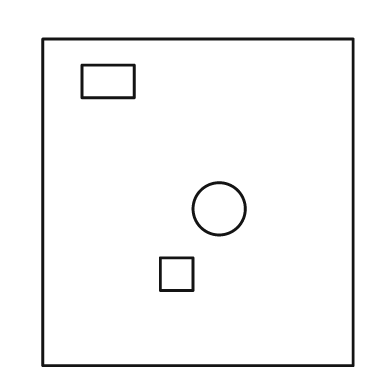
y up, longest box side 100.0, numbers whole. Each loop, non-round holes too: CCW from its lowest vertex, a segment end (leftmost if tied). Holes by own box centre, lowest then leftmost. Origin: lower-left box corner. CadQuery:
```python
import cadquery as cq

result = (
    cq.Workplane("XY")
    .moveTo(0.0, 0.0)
    .lineTo(95.0, 0.0)
    .lineTo(95.0, 100.0)
    .lineTo(0.0, 100.0)
    .close()
    .moveTo(36.0, 23.0)
    .lineTo(46.0, 23.0)
    .lineTo(46.0, 33.0)
    .lineTo(36.0, 33.0)
    .close()
    .moveTo(54.0, 48.0)
    .circle(8.0)
    .moveTo(12.0, 82.0)
    .lineTo(28.0, 82.0)
    .lineTo(28.0, 92.0)
    .lineTo(12.0, 92.0)
    .close()
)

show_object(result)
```